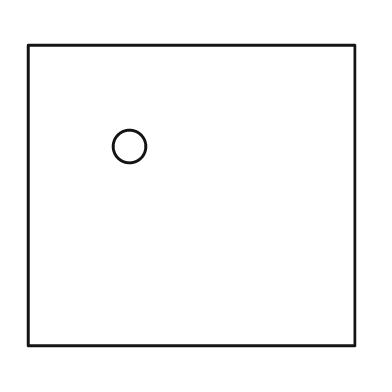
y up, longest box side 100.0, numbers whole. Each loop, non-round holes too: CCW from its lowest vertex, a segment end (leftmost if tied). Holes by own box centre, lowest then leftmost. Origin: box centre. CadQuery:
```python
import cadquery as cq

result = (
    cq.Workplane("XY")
    .moveTo(-50.0, -46.0)
    .lineTo(50.0, -46.0)
    .lineTo(50.0, 46.0)
    .lineTo(-50.0, 46.0)
    .close()
    .moveTo(-19.0, 15.0)
    .circle(5.0)
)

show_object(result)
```